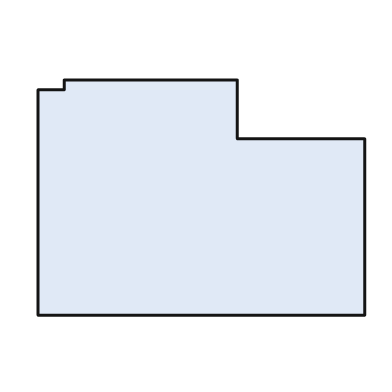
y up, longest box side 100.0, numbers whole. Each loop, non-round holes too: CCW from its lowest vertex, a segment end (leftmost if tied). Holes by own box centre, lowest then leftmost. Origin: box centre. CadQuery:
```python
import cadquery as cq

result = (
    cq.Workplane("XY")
    .moveTo(-50.0, -36.0)
    .lineTo(50.0, -36.0)
    .lineTo(50.0, 18.0)
    .lineTo(11.0, 18.0)
    .lineTo(11.0, 36.0)
    .lineTo(-42.0, 36.0)
    .lineTo(-42.0, 33.0)
    .lineTo(-50.0, 33.0)
    .close()
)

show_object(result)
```